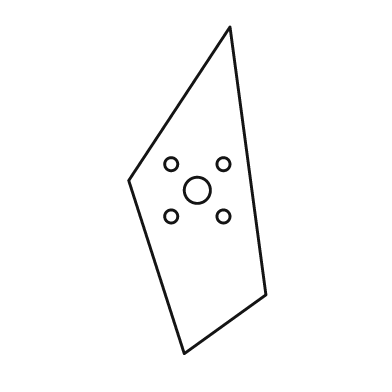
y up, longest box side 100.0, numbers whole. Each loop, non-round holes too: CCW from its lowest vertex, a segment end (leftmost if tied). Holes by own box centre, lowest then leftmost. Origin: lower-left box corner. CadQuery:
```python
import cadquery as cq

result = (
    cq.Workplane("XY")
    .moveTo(17.0, 0.0)
    .lineTo(42.0, 18.0)
    .lineTo(31.0, 100.0)
    .lineTo(0.0, 53.0)
    .close()
    .moveTo(13.0, 42.0)
    .circle(2.0)
    .moveTo(29.0, 42.0)
    .circle(2.0)
    .moveTo(21.0, 50.0)
    .circle(4.0)
    .moveTo(13.0, 58.0)
    .circle(2.0)
    .moveTo(29.0, 58.0)
    .circle(2.0)
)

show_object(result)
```